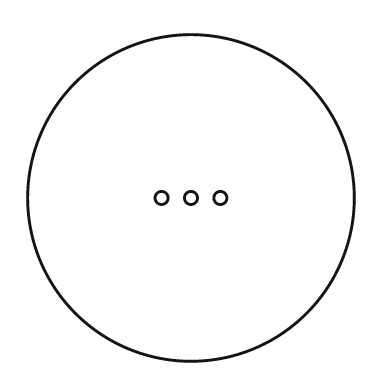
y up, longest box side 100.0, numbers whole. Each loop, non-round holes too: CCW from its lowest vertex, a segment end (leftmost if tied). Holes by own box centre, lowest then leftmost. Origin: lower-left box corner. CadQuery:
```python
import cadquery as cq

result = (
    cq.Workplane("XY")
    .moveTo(50.0, 50.0)
    .circle(50.0)
    .moveTo(41.0, 50.0)
    .circle(2.0)
    .moveTo(50.0, 50.0)
    .circle(2.0)
    .moveTo(59.0, 50.0)
    .circle(2.0)
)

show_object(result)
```